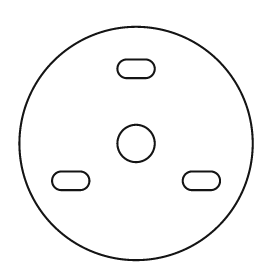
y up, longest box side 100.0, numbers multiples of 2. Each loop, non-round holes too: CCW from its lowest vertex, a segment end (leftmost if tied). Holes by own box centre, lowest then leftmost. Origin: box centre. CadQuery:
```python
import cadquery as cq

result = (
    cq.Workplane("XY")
    .moveTo(0.0, 0.0)
    .circle(50.0)
    .moveTo(-32.0, -20.0)
    .lineTo(-24.0, -20.0)
    .threePointArc((-20.0, -16.0), (-24.0, -12.0))
    .lineTo(-32.0, -12.0)
    .threePointArc((-36.0, -16.0), (-32.0, -20.0))
    .close()
    .moveTo(24.0, -20.0)
    .lineTo(32.0, -20.0)
    .threePointArc((36.0, -16.0), (32.0, -12.0))
    .lineTo(24.0, -12.0)
    .threePointArc((20.0, -16.0), (24.0, -20.0))
    .close()
    .moveTo(0.0, 0.0)
    .circle(8.0)
    .moveTo(-4.0, 28.0)
    .lineTo(4.0, 28.0)
    .threePointArc((8.0, 32.0), (4.0, 36.0))
    .lineTo(-4.0, 36.0)
    .threePointArc((-8.0, 32.0), (-4.0, 28.0))
    .close()
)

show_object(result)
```